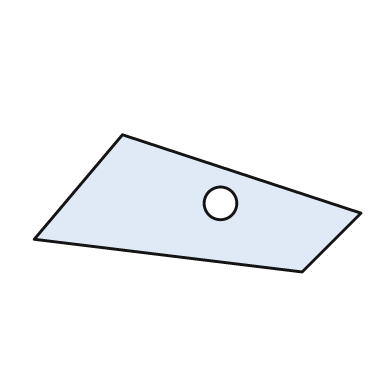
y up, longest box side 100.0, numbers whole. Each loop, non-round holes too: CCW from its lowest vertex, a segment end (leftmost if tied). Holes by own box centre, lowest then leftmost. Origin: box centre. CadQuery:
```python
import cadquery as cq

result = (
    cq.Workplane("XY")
    .moveTo(32.0, -21.0)
    .lineTo(50.0, -3.0)
    .lineTo(-23.0, 21.0)
    .lineTo(-50.0, -11.0)
    .close()
    .moveTo(7.0, 0.0)
    .circle(5.0)
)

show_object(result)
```